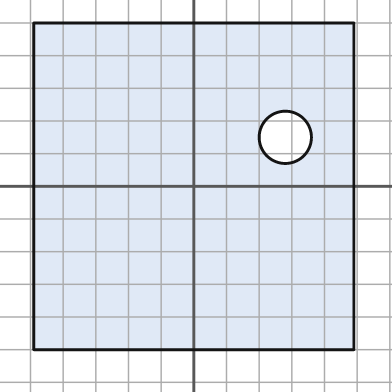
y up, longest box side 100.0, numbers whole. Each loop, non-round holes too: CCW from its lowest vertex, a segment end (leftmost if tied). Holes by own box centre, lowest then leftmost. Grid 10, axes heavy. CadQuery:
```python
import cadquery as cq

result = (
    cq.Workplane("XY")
    .moveTo(-49.0, -50.0)
    .lineTo(49.0, -50.0)
    .lineTo(49.0, 50.0)
    .lineTo(-49.0, 50.0)
    .close()
    .moveTo(28.0, 15.0)
    .circle(8.0)
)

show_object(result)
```